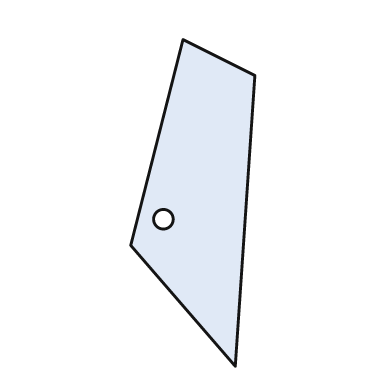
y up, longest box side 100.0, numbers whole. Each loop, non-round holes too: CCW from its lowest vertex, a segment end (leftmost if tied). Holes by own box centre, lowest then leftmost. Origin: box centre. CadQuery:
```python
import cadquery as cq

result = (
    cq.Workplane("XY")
    .moveTo(13.0, -50.0)
    .lineTo(19.0, 39.0)
    .lineTo(-3.0, 50.0)
    .lineTo(-19.0, -13.0)
    .close()
    .moveTo(-9.0, -5.0)
    .circle(3.0)
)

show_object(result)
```